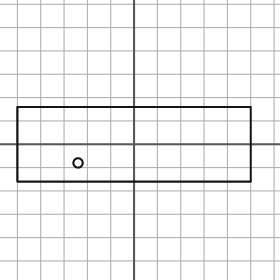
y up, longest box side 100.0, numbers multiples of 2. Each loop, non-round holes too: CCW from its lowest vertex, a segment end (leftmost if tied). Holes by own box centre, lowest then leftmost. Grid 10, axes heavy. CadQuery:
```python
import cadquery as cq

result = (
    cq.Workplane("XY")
    .moveTo(-50.0, -16.0)
    .lineTo(50.0, -16.0)
    .lineTo(50.0, 16.0)
    .lineTo(-50.0, 16.0)
    .close()
    .moveTo(-24.0, -8.0)
    .circle(2.0)
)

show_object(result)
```